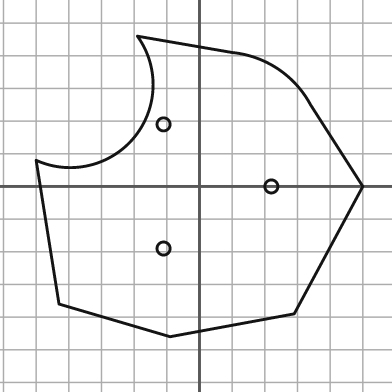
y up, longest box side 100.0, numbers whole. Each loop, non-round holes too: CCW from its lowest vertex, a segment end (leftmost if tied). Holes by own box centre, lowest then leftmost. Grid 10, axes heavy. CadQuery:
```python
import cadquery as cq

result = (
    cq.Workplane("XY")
    .moveTo(-9.0, -46.0)
    .lineTo(29.0, -39.0)
    .lineTo(50.0, 0.0)
    .lineTo(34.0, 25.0)
    .threePointArc((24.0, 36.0), (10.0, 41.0))
    .lineTo(-19.0, 46.0)
    .threePointArc((-20.0, 15.0), (-50.0, 8.0))
    .lineTo(-43.0, -36.0)
    .close()
    .moveTo(-11.0, -19.0)
    .circle(2.0)
    .moveTo(22.0, 0.0)
    .circle(2.0)
    .moveTo(-11.0, 19.0)
    .circle(2.0)
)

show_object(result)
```